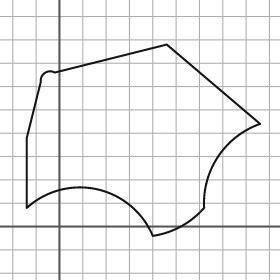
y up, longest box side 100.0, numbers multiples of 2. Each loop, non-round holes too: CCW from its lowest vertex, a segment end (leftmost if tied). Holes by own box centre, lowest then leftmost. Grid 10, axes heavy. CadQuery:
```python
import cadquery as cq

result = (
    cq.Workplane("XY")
    .moveTo(40.0, -4.0)
    .threePointArc((52.0, 0.0), (62.0, 8.0))
    .threePointArc((68.0, 30.0), (86.0, 44.0))
    .lineTo(46.0, 78.0)
    .lineTo(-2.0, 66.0)
    .threePointArc((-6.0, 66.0), (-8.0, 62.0))
    .lineTo(-14.0, 38.0)
    .lineTo(-14.0, 8.0)
    .threePointArc((16.0, 16.0), (40.0, -4.0))
    .close()
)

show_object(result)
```